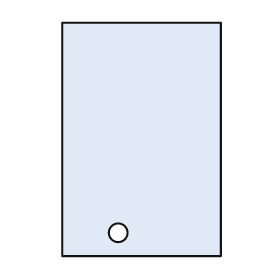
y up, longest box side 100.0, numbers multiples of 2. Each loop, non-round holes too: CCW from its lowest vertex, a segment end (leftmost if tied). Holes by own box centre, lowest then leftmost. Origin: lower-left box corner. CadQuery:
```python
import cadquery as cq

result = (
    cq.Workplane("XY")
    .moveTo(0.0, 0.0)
    .lineTo(68.0, 0.0)
    .lineTo(68.0, 100.0)
    .lineTo(0.0, 100.0)
    .close()
    .moveTo(24.0, 10.0)
    .circle(4.0)
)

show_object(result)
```